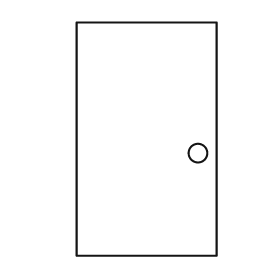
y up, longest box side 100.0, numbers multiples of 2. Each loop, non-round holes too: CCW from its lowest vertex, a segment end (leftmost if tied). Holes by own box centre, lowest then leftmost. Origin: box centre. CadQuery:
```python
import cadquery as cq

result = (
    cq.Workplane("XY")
    .moveTo(-30.0, -50.0)
    .lineTo(30.0, -50.0)
    .lineTo(30.0, 50.0)
    .lineTo(-30.0, 50.0)
    .close()
    .moveTo(22.0, -6.0)
    .circle(4.0)
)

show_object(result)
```